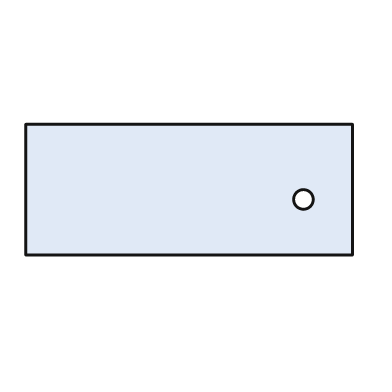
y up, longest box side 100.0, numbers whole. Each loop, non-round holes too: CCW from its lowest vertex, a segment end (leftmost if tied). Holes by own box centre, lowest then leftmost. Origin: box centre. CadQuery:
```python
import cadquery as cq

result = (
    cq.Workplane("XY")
    .moveTo(-50.0, -20.0)
    .lineTo(50.0, -20.0)
    .lineTo(50.0, 20.0)
    .lineTo(-50.0, 20.0)
    .close()
    .moveTo(35.0, -3.0)
    .circle(3.0)
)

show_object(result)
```